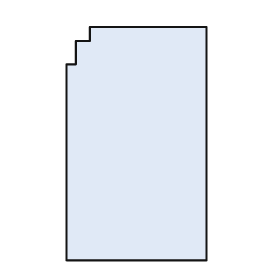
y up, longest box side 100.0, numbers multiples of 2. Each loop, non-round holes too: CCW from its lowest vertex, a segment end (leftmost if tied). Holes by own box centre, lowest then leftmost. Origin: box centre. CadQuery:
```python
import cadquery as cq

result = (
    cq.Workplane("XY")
    .moveTo(-30.0, -50.0)
    .lineTo(30.0, -50.0)
    .lineTo(30.0, 50.0)
    .lineTo(-20.0, 50.0)
    .lineTo(-20.0, 44.0)
    .lineTo(-26.0, 44.0)
    .lineTo(-26.0, 34.0)
    .lineTo(-30.0, 34.0)
    .close()
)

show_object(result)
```